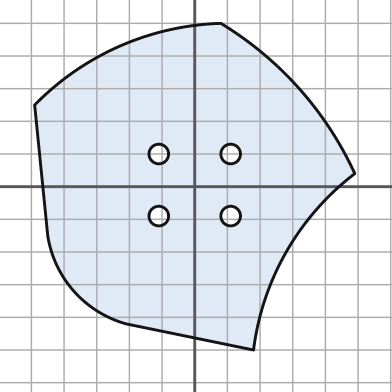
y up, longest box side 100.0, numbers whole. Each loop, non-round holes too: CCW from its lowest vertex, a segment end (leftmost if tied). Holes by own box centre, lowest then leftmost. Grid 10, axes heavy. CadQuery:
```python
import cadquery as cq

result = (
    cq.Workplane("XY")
    .moveTo(18.0, -50.0)
    .threePointArc((28.0, -20.0), (49.0, 4.0))
    .threePointArc((32.0, 30.0), (8.0, 50.0))
    .threePointArc((-23.0, 43.0), (-49.0, 25.0))
    .lineTo(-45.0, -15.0)
    .threePointArc((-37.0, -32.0), (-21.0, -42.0))
    .close()
    .moveTo(-11.0, -9.0)
    .circle(3.0)
    .moveTo(11.0, -9.0)
    .circle(3.0)
    .moveTo(-11.0, 10.0)
    .circle(3.0)
    .moveTo(11.0, 10.0)
    .circle(3.0)
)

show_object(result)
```